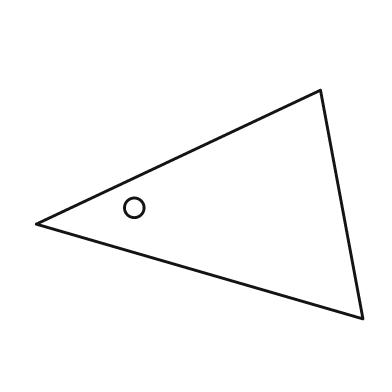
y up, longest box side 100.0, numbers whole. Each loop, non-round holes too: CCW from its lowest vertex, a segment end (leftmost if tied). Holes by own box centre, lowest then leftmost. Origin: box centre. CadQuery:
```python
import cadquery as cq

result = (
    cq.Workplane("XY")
    .moveTo(50.0, -35.0)
    .lineTo(37.0, 35.0)
    .lineTo(-50.0, -6.0)
    .close()
    .moveTo(-20.0, -1.0)
    .circle(3.0)
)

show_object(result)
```